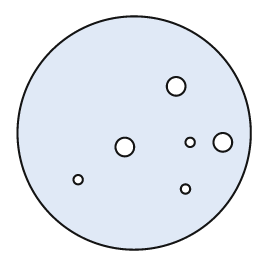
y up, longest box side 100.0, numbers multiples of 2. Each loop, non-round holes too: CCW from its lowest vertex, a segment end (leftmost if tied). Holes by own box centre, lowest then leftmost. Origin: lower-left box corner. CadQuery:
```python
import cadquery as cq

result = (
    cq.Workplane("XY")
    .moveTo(50.0, 50.0)
    .circle(50.0)
    .moveTo(72.0, 26.0)
    .circle(2.0)
    .moveTo(26.0, 30.0)
    .circle(2.0)
    .moveTo(46.0, 44.0)
    .circle(4.0)
    .moveTo(74.0, 46.0)
    .circle(2.0)
    .moveTo(88.0, 46.0)
    .circle(4.0)
    .moveTo(68.0, 70.0)
    .circle(4.0)
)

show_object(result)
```